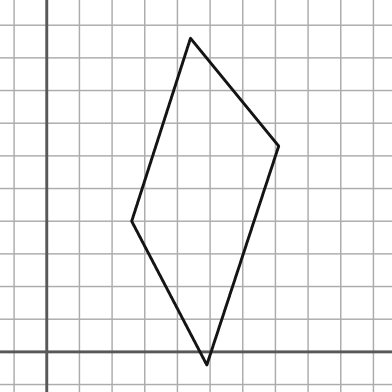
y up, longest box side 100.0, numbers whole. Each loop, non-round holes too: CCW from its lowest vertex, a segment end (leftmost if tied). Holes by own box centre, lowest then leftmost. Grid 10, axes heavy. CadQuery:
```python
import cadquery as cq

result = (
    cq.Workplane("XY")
    .moveTo(49.0, -4.0)
    .lineTo(71.0, 63.0)
    .lineTo(44.0, 96.0)
    .lineTo(26.0, 40.0)
    .close()
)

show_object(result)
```